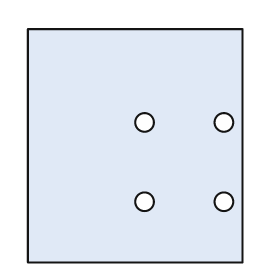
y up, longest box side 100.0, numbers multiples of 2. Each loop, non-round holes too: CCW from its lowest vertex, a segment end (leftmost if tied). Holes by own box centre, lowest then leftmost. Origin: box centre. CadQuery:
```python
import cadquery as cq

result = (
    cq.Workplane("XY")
    .moveTo(-46.0, -50.0)
    .lineTo(46.0, -50.0)
    .lineTo(46.0, 50.0)
    .lineTo(-46.0, 50.0)
    .close()
    .moveTo(4.0, -24.0)
    .circle(4.0)
    .moveTo(38.0, -24.0)
    .circle(4.0)
    .moveTo(4.0, 10.0)
    .circle(4.0)
    .moveTo(38.0, 10.0)
    .circle(4.0)
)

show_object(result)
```